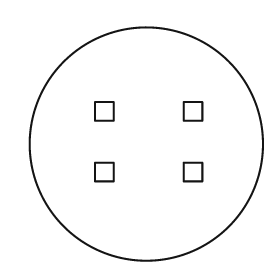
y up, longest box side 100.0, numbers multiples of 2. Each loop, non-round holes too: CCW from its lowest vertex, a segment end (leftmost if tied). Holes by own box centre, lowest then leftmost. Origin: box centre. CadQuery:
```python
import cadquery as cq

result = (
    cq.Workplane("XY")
    .moveTo(0.0, 0.0)
    .circle(50.0)
    .moveTo(-22.0, -16.0)
    .lineTo(-14.0, -16.0)
    .lineTo(-14.0, -8.0)
    .lineTo(-22.0, -8.0)
    .close()
    .moveTo(16.0, -16.0)
    .lineTo(24.0, -16.0)
    .lineTo(24.0, -8.0)
    .lineTo(16.0, -8.0)
    .close()
    .moveTo(-22.0, 10.0)
    .lineTo(-14.0, 10.0)
    .lineTo(-14.0, 18.0)
    .lineTo(-22.0, 18.0)
    .close()
    .moveTo(16.0, 10.0)
    .lineTo(24.0, 10.0)
    .lineTo(24.0, 18.0)
    .lineTo(16.0, 18.0)
    .close()
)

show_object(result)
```